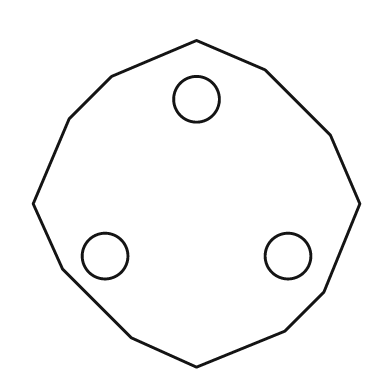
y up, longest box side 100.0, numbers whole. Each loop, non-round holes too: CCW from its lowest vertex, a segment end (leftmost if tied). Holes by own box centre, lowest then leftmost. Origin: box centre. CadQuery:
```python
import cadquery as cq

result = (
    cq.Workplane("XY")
    .moveTo(0.0, -50.0)
    .lineTo(27.0, -39.0)
    .lineTo(39.0, -27.0)
    .lineTo(50.0, 0.0)
    .lineTo(41.0, 21.0)
    .lineTo(21.0, 41.0)
    .lineTo(0.0, 50.0)
    .lineTo(-26.0, 39.0)
    .lineTo(-39.0, 26.0)
    .lineTo(-50.0, 0.0)
    .lineTo(-41.0, -20.0)
    .lineTo(-20.0, -41.0)
    .close()
    .moveTo(-28.0, -16.0)
    .circle(7.0)
    .moveTo(28.0, -16.0)
    .circle(7.0)
    .moveTo(0.0, 32.0)
    .circle(7.0)
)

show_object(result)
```